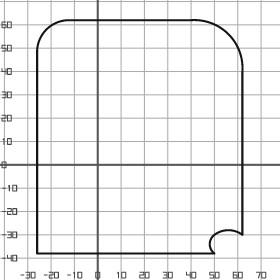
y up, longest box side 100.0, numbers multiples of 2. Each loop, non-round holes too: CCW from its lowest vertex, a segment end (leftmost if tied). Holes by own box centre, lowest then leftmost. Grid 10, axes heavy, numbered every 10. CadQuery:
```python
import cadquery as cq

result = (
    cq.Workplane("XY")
    .moveTo(-26.0, -38.0)
    .lineTo(50.0, -38.0)
    .threePointArc((48.0, -34.0), (50.0, -30.0))
    .threePointArc((56.0, -28.0), (62.0, -30.0))
    .lineTo(62.0, 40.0)
    .threePointArc((56.0, 56.0), (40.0, 62.0))
    .lineTo(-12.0, 62.0)
    .threePointArc((-22.0, 58.0), (-26.0, 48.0))
    .close()
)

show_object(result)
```